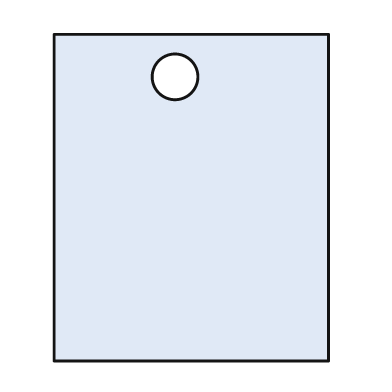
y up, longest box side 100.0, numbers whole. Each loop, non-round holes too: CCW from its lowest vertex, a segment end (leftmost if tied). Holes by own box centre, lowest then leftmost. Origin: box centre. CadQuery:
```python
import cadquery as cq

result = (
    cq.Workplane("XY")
    .moveTo(-42.0, -50.0)
    .lineTo(42.0, -50.0)
    .lineTo(42.0, 50.0)
    .lineTo(-42.0, 50.0)
    .close()
    .moveTo(-5.0, 37.0)
    .circle(7.0)
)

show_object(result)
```